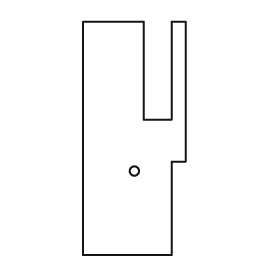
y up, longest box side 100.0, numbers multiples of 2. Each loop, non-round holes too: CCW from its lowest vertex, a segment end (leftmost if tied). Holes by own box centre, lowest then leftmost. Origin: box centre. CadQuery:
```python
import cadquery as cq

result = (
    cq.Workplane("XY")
    .moveTo(-22.0, -50.0)
    .lineTo(16.0, -50.0)
    .lineTo(16.0, -10.0)
    .lineTo(22.0, -10.0)
    .lineTo(22.0, 50.0)
    .lineTo(16.0, 50.0)
    .lineTo(16.0, 8.0)
    .lineTo(4.0, 8.0)
    .lineTo(4.0, 50.0)
    .lineTo(-22.0, 50.0)
    .close()
    .moveTo(0.0, -14.0)
    .circle(2.0)
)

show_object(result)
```